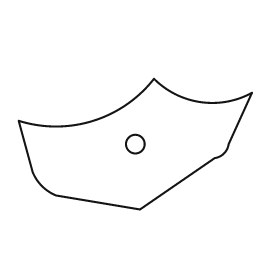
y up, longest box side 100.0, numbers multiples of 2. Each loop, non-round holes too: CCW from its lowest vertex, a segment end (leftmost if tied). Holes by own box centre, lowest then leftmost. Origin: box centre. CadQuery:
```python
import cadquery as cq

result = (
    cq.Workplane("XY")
    .moveTo(2.0, -28.0)
    .lineTo(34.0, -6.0)
    .threePointArc((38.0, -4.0), (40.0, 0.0))
    .lineTo(50.0, 22.0)
    .threePointArc((28.0, 18.0), (8.0, 28.0))
    .threePointArc((-18.0, 10.0), (-50.0, 10.0))
    .lineTo(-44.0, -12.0)
    .threePointArc((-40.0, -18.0), (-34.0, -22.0))
    .close()
    .moveTo(0.0, 0.0)
    .circle(4.0)
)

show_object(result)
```